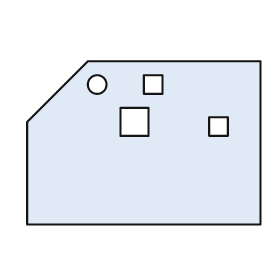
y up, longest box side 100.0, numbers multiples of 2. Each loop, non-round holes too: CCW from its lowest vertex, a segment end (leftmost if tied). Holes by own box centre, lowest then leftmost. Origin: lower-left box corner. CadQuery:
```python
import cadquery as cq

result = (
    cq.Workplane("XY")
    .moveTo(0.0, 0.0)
    .lineTo(100.0, 0.0)
    .lineTo(100.0, 70.0)
    .lineTo(26.0, 70.0)
    .lineTo(0.0, 44.0)
    .close()
    .moveTo(78.0, 38.0)
    .lineTo(86.0, 38.0)
    .lineTo(86.0, 46.0)
    .lineTo(78.0, 46.0)
    .close()
    .moveTo(40.0, 38.0)
    .lineTo(52.0, 38.0)
    .lineTo(52.0, 50.0)
    .lineTo(40.0, 50.0)
    .close()
    .moveTo(30.0, 60.0)
    .circle(4.0)
    .moveTo(50.0, 56.0)
    .lineTo(58.0, 56.0)
    .lineTo(58.0, 64.0)
    .lineTo(50.0, 64.0)
    .close()
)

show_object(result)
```